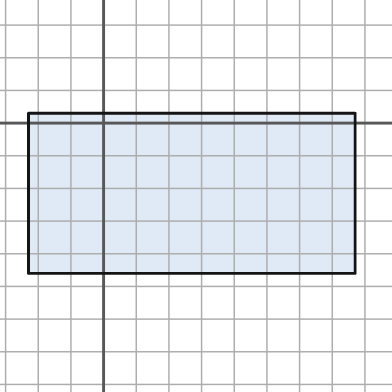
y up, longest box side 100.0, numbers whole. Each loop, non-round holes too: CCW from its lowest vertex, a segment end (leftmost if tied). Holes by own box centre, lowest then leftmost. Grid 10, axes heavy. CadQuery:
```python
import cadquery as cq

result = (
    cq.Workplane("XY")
    .moveTo(-23.0, -46.0)
    .lineTo(77.0, -46.0)
    .lineTo(77.0, 3.0)
    .lineTo(-23.0, 3.0)
    .close()
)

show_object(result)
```